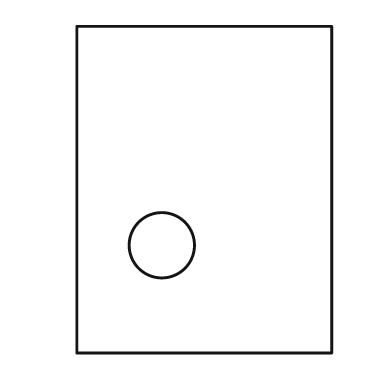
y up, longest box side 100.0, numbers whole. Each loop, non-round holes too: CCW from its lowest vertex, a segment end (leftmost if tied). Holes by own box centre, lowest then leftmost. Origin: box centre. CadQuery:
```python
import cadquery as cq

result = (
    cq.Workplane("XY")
    .moveTo(-39.0, -50.0)
    .lineTo(39.0, -50.0)
    .lineTo(39.0, 50.0)
    .lineTo(-39.0, 50.0)
    .close()
    .moveTo(-13.0, -17.0)
    .circle(10.0)
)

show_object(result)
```